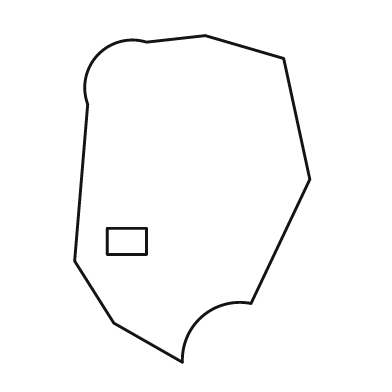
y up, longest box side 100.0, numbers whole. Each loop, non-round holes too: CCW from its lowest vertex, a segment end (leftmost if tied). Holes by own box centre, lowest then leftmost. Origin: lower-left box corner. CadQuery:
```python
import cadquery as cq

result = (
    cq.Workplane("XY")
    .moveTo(33.0, 0.0)
    .threePointArc((39.0, 14.0), (54.0, 18.0))
    .lineTo(72.0, 56.0)
    .lineTo(64.0, 93.0)
    .lineTo(40.0, 100.0)
    .lineTo(22.0, 98.0)
    .threePointArc((7.0, 94.0), (4.0, 79.0))
    .lineTo(0.0, 31.0)
    .lineTo(12.0, 12.0)
    .close()
    .moveTo(10.0, 33.0)
    .lineTo(22.0, 33.0)
    .lineTo(22.0, 41.0)
    .lineTo(10.0, 41.0)
    .close()
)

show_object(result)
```